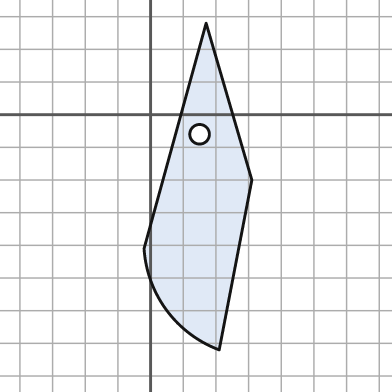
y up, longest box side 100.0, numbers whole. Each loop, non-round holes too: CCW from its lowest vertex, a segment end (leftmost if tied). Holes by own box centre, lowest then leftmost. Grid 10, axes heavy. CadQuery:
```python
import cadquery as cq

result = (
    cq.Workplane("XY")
    .moveTo(21.0, -72.0)
    .lineTo(31.0, -20.0)
    .lineTo(17.0, 28.0)
    .lineTo(-2.0, -41.0)
    .threePointArc((5.0, -60.0), (21.0, -72.0))
    .close()
    .moveTo(15.0, -6.0)
    .circle(3.0)
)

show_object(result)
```